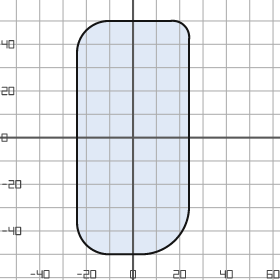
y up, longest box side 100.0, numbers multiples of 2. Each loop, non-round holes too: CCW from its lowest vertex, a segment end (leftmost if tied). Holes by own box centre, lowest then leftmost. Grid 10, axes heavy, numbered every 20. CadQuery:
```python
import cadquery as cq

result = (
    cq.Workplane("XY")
    .moveTo(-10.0, -50.0)
    .lineTo(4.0, -50.0)
    .threePointArc((18.0, -44.0), (24.0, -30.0))
    .lineTo(24.0, 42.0)
    .threePointArc((22.0, 48.0), (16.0, 50.0))
    .lineTo(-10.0, 50.0)
    .threePointArc((-20.0, 46.0), (-24.0, 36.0))
    .lineTo(-24.0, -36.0)
    .threePointArc((-20.0, -46.0), (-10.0, -50.0))
    .close()
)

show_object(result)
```